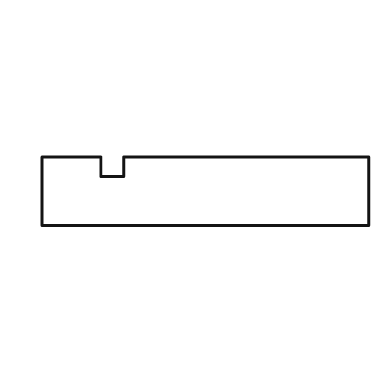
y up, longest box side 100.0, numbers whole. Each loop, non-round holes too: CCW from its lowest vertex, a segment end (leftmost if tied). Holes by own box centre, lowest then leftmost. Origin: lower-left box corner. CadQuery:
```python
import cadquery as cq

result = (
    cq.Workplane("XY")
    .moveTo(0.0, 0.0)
    .lineTo(100.0, 0.0)
    .lineTo(100.0, 21.0)
    .lineTo(25.0, 21.0)
    .lineTo(25.0, 15.0)
    .lineTo(18.0, 15.0)
    .lineTo(18.0, 21.0)
    .lineTo(0.0, 21.0)
    .close()
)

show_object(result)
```